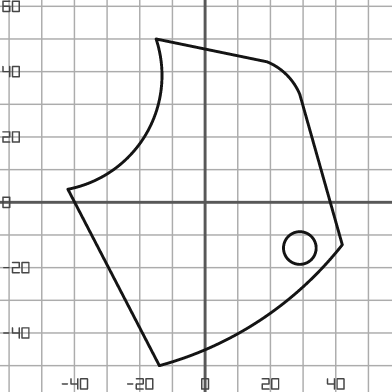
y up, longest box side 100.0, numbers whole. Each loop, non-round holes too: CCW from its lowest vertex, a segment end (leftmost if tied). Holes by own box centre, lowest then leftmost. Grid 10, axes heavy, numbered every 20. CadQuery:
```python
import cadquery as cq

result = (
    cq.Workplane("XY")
    .moveTo(-14.0, -50.0)
    .threePointArc((17.0, -36.0), (42.0, -13.0))
    .lineTo(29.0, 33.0)
    .threePointArc((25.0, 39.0), (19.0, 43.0))
    .lineTo(-15.0, 50.0)
    .threePointArc((-18.0, 21.0), (-42.0, 4.0))
    .close()
    .moveTo(29.0, -14.0)
    .circle(5.0)
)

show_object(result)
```